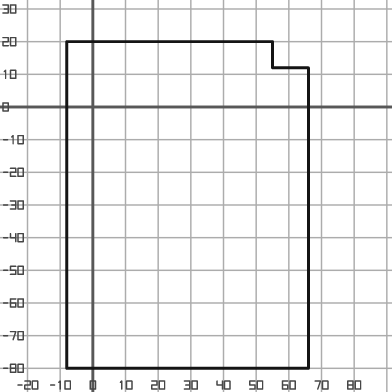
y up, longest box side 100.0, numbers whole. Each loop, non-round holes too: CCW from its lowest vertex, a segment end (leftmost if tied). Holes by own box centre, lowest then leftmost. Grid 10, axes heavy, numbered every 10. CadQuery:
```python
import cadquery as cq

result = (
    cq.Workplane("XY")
    .moveTo(-8.0, -80.0)
    .lineTo(66.0, -80.0)
    .lineTo(66.0, 12.0)
    .lineTo(55.0, 12.0)
    .lineTo(55.0, 20.0)
    .lineTo(-8.0, 20.0)
    .close()
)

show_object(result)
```